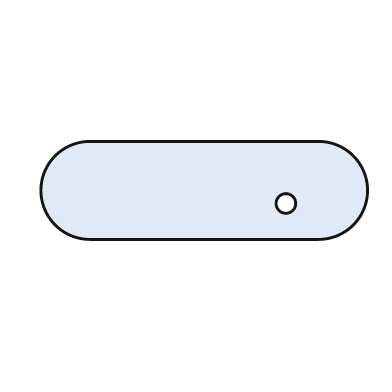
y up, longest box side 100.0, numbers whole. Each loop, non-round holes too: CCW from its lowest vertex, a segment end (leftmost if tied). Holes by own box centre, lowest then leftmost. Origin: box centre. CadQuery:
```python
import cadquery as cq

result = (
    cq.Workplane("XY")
    .moveTo(-35.0, -15.0)
    .lineTo(35.0, -15.0)
    .threePointArc((50.0, 0.0), (35.0, 15.0))
    .lineTo(-35.0, 15.0)
    .threePointArc((-50.0, 0.0), (-35.0, -15.0))
    .close()
    .moveTo(25.0, -4.0)
    .circle(3.0)
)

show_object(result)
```